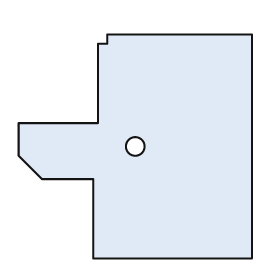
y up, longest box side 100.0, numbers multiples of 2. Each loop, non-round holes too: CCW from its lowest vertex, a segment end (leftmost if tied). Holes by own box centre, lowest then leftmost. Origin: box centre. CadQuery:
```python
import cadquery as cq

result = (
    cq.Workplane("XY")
    .moveTo(-18.0, -48.0)
    .lineTo(50.0, -48.0)
    .lineTo(50.0, 48.0)
    .lineTo(-12.0, 48.0)
    .lineTo(-12.0, 44.0)
    .lineTo(-16.0, 44.0)
    .lineTo(-16.0, 10.0)
    .lineTo(-50.0, 10.0)
    .lineTo(-50.0, -4.0)
    .lineTo(-40.0, -14.0)
    .lineTo(-18.0, -14.0)
    .close()
    .moveTo(0.0, 0.0)
    .circle(4.0)
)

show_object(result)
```